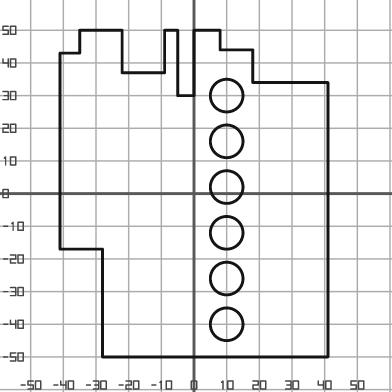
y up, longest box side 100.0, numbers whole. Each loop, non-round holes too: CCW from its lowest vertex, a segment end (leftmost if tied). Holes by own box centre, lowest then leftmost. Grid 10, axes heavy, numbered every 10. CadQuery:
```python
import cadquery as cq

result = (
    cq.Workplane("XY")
    .moveTo(-28.0, -50.0)
    .lineTo(41.0, -50.0)
    .lineTo(41.0, 34.0)
    .lineTo(18.0, 34.0)
    .lineTo(18.0, 44.0)
    .lineTo(8.0, 44.0)
    .lineTo(8.0, 50.0)
    .lineTo(0.0, 50.0)
    .lineTo(0.0, 30.0)
    .lineTo(-5.0, 30.0)
    .lineTo(-5.0, 50.0)
    .lineTo(-9.0, 50.0)
    .lineTo(-9.0, 37.0)
    .lineTo(-22.0, 37.0)
    .lineTo(-22.0, 50.0)
    .lineTo(-35.0, 50.0)
    .lineTo(-35.0, 43.0)
    .lineTo(-41.0, 43.0)
    .lineTo(-41.0, -17.0)
    .lineTo(-28.0, -17.0)
    .close()
    .moveTo(10.0, -40.0)
    .circle(5.0)
    .moveTo(10.0, -26.0)
    .circle(5.0)
    .moveTo(10.0, -12.0)
    .circle(5.0)
    .moveTo(10.0, 2.0)
    .circle(5.0)
    .moveTo(10.0, 16.0)
    .circle(5.0)
    .moveTo(10.0, 30.0)
    .circle(5.0)
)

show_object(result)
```